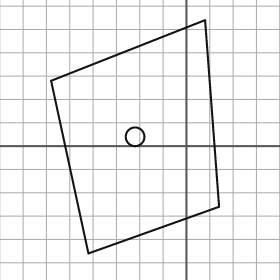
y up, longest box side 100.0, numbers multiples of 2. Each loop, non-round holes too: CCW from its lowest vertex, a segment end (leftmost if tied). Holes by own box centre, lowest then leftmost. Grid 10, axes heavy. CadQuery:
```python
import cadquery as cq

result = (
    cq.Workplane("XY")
    .moveTo(-42.0, -46.0)
    .lineTo(14.0, -26.0)
    .lineTo(8.0, 54.0)
    .lineTo(-58.0, 28.0)
    .close()
    .moveTo(-22.0, 4.0)
    .circle(4.0)
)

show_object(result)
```